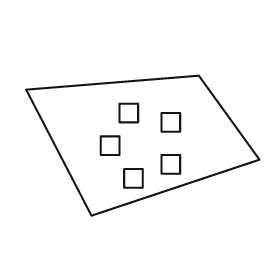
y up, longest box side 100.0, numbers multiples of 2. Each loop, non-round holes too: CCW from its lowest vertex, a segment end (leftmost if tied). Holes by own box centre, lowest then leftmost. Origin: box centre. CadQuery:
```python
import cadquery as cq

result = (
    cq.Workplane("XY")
    .moveTo(-22.0, -30.0)
    .lineTo(50.0, -6.0)
    .lineTo(24.0, 30.0)
    .lineTo(-50.0, 24.0)
    .close()
    .moveTo(-8.0, -18.0)
    .lineTo(0.0, -18.0)
    .lineTo(0.0, -10.0)
    .lineTo(-8.0, -10.0)
    .close()
    .moveTo(8.0, -12.0)
    .lineTo(16.0, -12.0)
    .lineTo(16.0, -4.0)
    .lineTo(8.0, -4.0)
    .close()
    .moveTo(-18.0, -4.0)
    .lineTo(-10.0, -4.0)
    .lineTo(-10.0, 4.0)
    .lineTo(-18.0, 4.0)
    .close()
    .moveTo(8.0, 6.0)
    .lineTo(16.0, 6.0)
    .lineTo(16.0, 14.0)
    .lineTo(8.0, 14.0)
    .close()
    .moveTo(-10.0, 10.0)
    .lineTo(-2.0, 10.0)
    .lineTo(-2.0, 18.0)
    .lineTo(-10.0, 18.0)
    .close()
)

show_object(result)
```